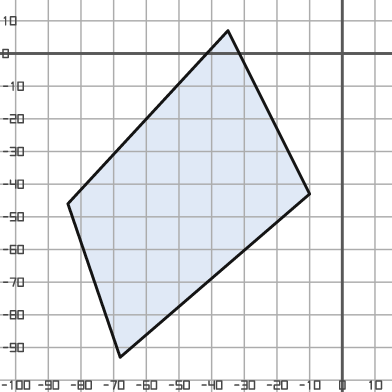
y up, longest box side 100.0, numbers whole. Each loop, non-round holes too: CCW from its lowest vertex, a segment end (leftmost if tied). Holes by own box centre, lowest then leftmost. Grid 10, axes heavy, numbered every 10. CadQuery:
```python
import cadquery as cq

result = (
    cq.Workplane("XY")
    .moveTo(-68.0, -93.0)
    .lineTo(-10.0, -43.0)
    .lineTo(-35.0, 7.0)
    .lineTo(-84.0, -46.0)
    .close()
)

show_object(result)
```